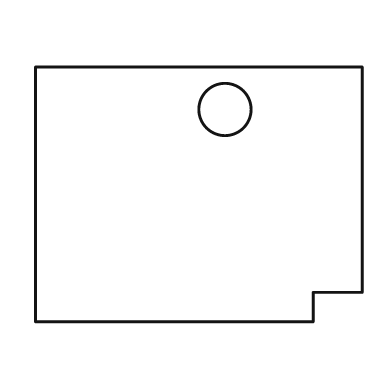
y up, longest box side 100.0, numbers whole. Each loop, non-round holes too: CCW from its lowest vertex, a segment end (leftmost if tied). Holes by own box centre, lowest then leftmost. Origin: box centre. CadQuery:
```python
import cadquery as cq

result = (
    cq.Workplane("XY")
    .moveTo(-50.0, -39.0)
    .lineTo(35.0, -39.0)
    .lineTo(35.0, -30.0)
    .lineTo(50.0, -30.0)
    .lineTo(50.0, 39.0)
    .lineTo(-50.0, 39.0)
    .close()
    .moveTo(8.0, 26.0)
    .circle(8.0)
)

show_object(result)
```